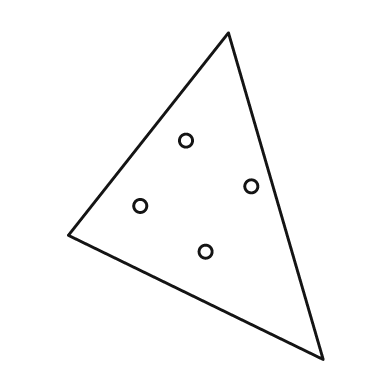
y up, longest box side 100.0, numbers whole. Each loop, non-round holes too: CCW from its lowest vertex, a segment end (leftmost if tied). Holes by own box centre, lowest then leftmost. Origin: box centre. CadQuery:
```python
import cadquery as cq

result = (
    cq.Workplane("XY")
    .moveTo(39.0, -50.0)
    .lineTo(10.0, 50.0)
    .lineTo(-39.0, -12.0)
    .close()
    .moveTo(3.0, -17.0)
    .circle(2.0)
    .moveTo(-17.0, -3.0)
    .circle(2.0)
    .moveTo(17.0, 3.0)
    .circle(2.0)
    .moveTo(-3.0, 17.0)
    .circle(2.0)
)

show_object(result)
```